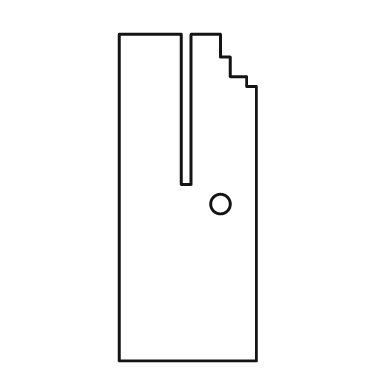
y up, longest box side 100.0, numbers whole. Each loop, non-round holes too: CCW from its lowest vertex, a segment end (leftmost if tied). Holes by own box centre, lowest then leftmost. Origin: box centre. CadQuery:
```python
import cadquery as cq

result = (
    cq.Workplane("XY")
    .moveTo(-21.0, -50.0)
    .lineTo(21.0, -50.0)
    .lineTo(21.0, 34.0)
    .lineTo(18.0, 34.0)
    .lineTo(18.0, 37.0)
    .lineTo(13.0, 37.0)
    .lineTo(13.0, 43.0)
    .lineTo(10.0, 43.0)
    .lineTo(10.0, 50.0)
    .lineTo(1.0, 50.0)
    .lineTo(1.0, 4.0)
    .lineTo(-2.0, 4.0)
    .lineTo(-2.0, 50.0)
    .lineTo(-21.0, 50.0)
    .close()
    .moveTo(10.0, -2.0)
    .circle(3.0)
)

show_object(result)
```